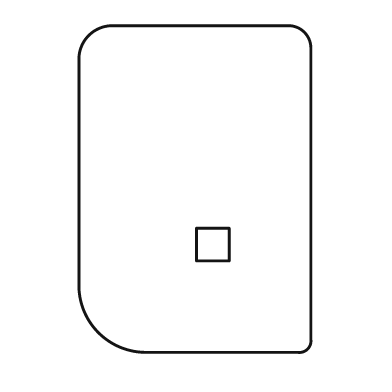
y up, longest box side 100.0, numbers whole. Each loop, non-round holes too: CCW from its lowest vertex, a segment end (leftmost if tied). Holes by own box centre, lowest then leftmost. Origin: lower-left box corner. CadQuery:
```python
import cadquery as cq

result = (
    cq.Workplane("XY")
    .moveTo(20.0, 0.0)
    .lineTo(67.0, 0.0)
    .threePointArc((70.0, 1.0), (71.0, 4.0))
    .lineTo(71.0, 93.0)
    .threePointArc((69.0, 98.0), (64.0, 100.0))
    .lineTo(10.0, 100.0)
    .threePointArc((3.0, 97.0), (0.0, 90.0))
    .lineTo(0.0, 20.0)
    .threePointArc((6.0, 6.0), (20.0, 0.0))
    .close()
    .moveTo(36.0, 28.0)
    .lineTo(46.0, 28.0)
    .lineTo(46.0, 38.0)
    .lineTo(36.0, 38.0)
    .close()
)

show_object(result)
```